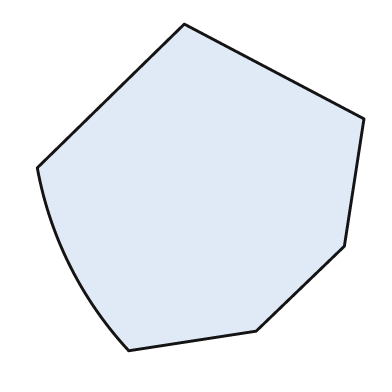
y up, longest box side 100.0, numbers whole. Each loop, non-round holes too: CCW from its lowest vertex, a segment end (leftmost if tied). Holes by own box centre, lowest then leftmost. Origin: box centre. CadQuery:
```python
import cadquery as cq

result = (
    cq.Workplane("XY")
    .moveTo(-22.0, -50.0)
    .lineTo(17.0, -44.0)
    .lineTo(44.0, -18.0)
    .lineTo(50.0, 21.0)
    .lineTo(-5.0, 50.0)
    .lineTo(-50.0, 6.0)
    .threePointArc((-40.0, -24.0), (-22.0, -50.0))
    .close()
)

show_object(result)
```